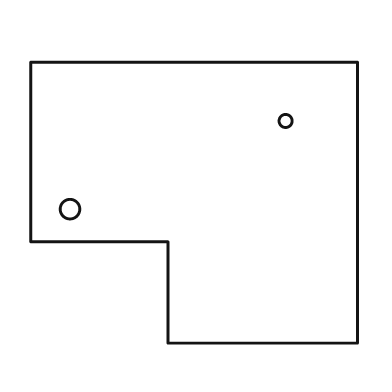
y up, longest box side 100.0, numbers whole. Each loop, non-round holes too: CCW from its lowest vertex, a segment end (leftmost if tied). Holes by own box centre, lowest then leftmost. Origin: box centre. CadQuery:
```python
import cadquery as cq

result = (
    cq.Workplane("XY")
    .moveTo(-8.0, -43.0)
    .lineTo(50.0, -43.0)
    .lineTo(50.0, 43.0)
    .lineTo(-50.0, 43.0)
    .lineTo(-50.0, -12.0)
    .lineTo(-8.0, -12.0)
    .close()
    .moveTo(-38.0, -2.0)
    .circle(3.0)
    .moveTo(28.0, 25.0)
    .circle(2.0)
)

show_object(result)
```